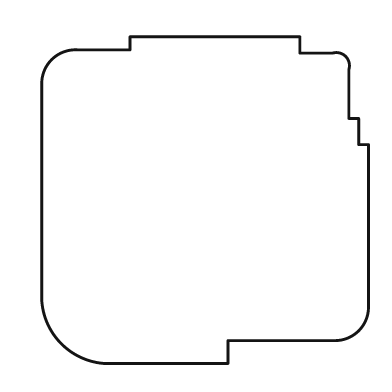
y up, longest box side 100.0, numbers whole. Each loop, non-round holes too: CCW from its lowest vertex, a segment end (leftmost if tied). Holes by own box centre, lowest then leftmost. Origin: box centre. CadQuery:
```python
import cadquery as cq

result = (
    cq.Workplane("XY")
    .moveTo(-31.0, -50.0)
    .lineTo(7.0, -50.0)
    .lineTo(7.0, -43.0)
    .lineTo(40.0, -43.0)
    .threePointArc((47.0, -40.0), (50.0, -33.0))
    .lineTo(50.0, 17.0)
    .lineTo(47.0, 17.0)
    .lineTo(47.0, 25.0)
    .lineTo(44.0, 25.0)
    .lineTo(44.0, 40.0)
    .threePointArc((43.0, 44.0), (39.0, 45.0))
    .lineTo(29.0, 45.0)
    .lineTo(29.0, 50.0)
    .lineTo(-23.0, 50.0)
    .lineTo(-23.0, 46.0)
    .lineTo(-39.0, 46.0)
    .threePointArc((-47.0, 43.0), (-50.0, 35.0))
    .lineTo(-50.0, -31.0)
    .threePointArc((-44.0, -44.0), (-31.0, -50.0))
    .close()
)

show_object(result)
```